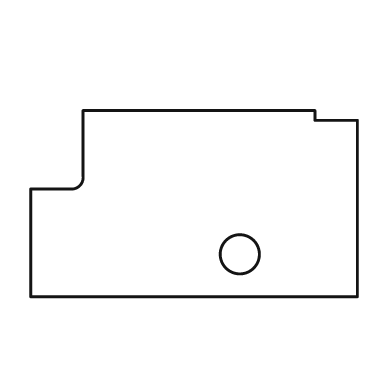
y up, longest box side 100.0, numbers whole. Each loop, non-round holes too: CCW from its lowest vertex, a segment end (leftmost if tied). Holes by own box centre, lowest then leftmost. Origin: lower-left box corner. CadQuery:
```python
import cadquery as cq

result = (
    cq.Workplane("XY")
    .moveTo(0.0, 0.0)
    .lineTo(100.0, 0.0)
    .lineTo(100.0, 54.0)
    .lineTo(87.0, 54.0)
    .lineTo(87.0, 57.0)
    .lineTo(16.0, 57.0)
    .lineTo(16.0, 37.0)
    .threePointArc((15.0, 34.0), (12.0, 33.0))
    .lineTo(0.0, 33.0)
    .close()
    .moveTo(64.0, 13.0)
    .circle(6.0)
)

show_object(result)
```